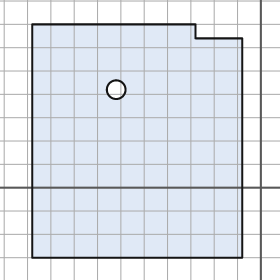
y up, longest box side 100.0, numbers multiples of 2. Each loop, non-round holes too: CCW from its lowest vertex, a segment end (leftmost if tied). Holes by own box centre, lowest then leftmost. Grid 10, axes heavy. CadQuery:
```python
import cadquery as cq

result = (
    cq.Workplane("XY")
    .moveTo(-98.0, -30.0)
    .lineTo(-8.0, -30.0)
    .lineTo(-8.0, 64.0)
    .lineTo(-28.0, 64.0)
    .lineTo(-28.0, 70.0)
    .lineTo(-98.0, 70.0)
    .close()
    .moveTo(-62.0, 42.0)
    .circle(4.0)
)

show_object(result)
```